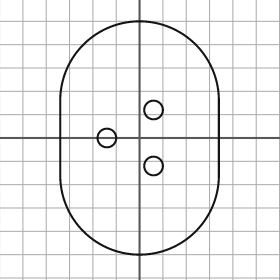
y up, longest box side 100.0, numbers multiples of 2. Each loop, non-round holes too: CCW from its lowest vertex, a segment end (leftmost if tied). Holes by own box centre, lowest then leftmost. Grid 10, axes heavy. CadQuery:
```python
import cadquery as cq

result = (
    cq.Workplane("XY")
    .moveTo(-34.0, -16.0)
    .threePointArc((0.0, -50.0), (34.0, -16.0))
    .lineTo(34.0, 16.0)
    .threePointArc((0.0, 50.0), (-34.0, 16.0))
    .close()
    .moveTo(6.0, -12.0)
    .circle(4.0)
    .moveTo(-14.0, 0.0)
    .circle(4.0)
    .moveTo(6.0, 12.0)
    .circle(4.0)
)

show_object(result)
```